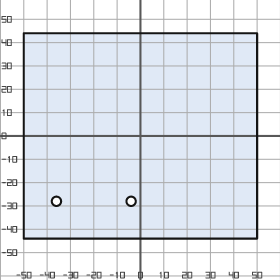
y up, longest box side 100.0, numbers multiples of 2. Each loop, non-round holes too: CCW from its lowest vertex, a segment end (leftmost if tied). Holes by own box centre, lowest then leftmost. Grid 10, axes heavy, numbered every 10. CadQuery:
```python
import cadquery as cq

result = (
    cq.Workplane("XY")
    .moveTo(-50.0, -44.0)
    .lineTo(50.0, -44.0)
    .lineTo(50.0, 44.0)
    .lineTo(-50.0, 44.0)
    .close()
    .moveTo(-36.0, -28.0)
    .circle(2.0)
    .moveTo(-4.0, -28.0)
    .circle(2.0)
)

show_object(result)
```